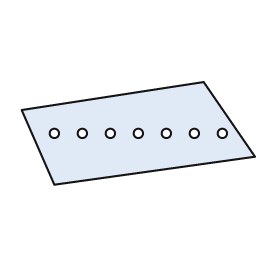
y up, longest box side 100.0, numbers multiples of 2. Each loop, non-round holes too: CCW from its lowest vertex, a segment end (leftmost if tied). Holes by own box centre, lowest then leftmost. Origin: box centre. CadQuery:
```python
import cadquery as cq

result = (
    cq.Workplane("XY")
    .moveTo(-36.0, -22.0)
    .lineTo(50.0, -10.0)
    .lineTo(28.0, 22.0)
    .lineTo(-50.0, 10.0)
    .close()
    .moveTo(-36.0, 0.0)
    .circle(2.0)
    .moveTo(-24.0, 0.0)
    .circle(2.0)
    .moveTo(-12.0, 0.0)
    .circle(2.0)
    .moveTo(0.0, 0.0)
    .circle(2.0)
    .moveTo(12.0, 0.0)
    .circle(2.0)
    .moveTo(24.0, 0.0)
    .circle(2.0)
    .moveTo(36.0, 0.0)
    .circle(2.0)
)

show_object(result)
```